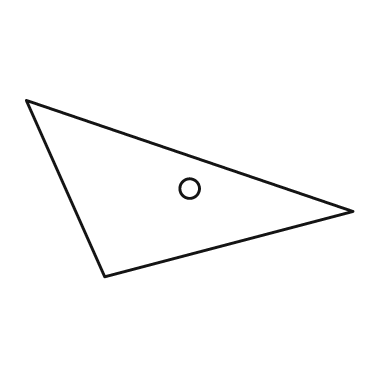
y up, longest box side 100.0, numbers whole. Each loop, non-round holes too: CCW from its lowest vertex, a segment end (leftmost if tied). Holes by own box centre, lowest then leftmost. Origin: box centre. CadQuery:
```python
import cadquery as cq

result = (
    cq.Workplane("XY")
    .moveTo(-26.0, -27.0)
    .lineTo(50.0, -7.0)
    .lineTo(-50.0, 27.0)
    .close()
    .moveTo(0.0, 0.0)
    .circle(3.0)
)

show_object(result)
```